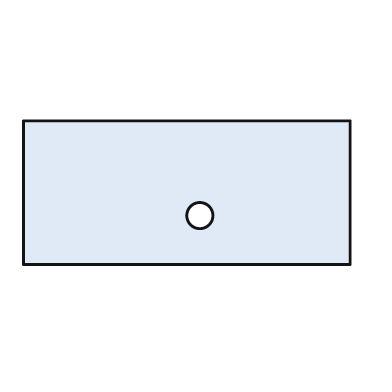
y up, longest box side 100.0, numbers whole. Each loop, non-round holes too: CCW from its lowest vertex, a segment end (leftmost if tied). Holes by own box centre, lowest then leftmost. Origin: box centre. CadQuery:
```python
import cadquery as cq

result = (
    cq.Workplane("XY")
    .moveTo(-50.0, -22.0)
    .lineTo(50.0, -22.0)
    .lineTo(50.0, 22.0)
    .lineTo(-50.0, 22.0)
    .close()
    .moveTo(4.0, -7.0)
    .circle(4.0)
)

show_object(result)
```